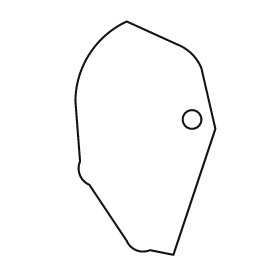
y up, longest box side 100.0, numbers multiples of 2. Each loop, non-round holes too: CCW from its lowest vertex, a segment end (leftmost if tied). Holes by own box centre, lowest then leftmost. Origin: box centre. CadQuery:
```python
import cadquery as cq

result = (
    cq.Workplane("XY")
    .moveTo(12.0, -50.0)
    .lineTo(30.0, 4.0)
    .lineTo(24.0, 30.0)
    .threePointArc((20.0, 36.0), (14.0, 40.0))
    .lineTo(-8.0, 50.0)
    .threePointArc((-24.0, 36.0), (-30.0, 16.0))
    .lineTo(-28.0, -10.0)
    .threePointArc((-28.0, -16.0), (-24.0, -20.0))
    .lineTo(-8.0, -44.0)
    .threePointArc((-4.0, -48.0), (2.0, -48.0))
    .close()
    .moveTo(20.0, 8.0)
    .circle(4.0)
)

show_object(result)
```